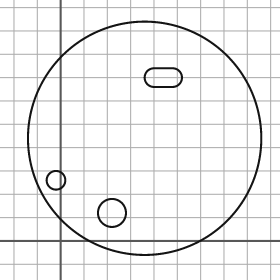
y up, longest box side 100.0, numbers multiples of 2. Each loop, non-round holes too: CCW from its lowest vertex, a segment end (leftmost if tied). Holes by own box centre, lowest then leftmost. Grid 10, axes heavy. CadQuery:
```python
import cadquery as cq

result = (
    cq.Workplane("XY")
    .moveTo(36.0, 44.0)
    .circle(50.0)
    .moveTo(22.0, 12.0)
    .circle(6.0)
    .moveTo(-2.0, 26.0)
    .circle(4.0)
    .moveTo(40.0, 66.0)
    .lineTo(48.0, 66.0)
    .threePointArc((52.0, 70.0), (48.0, 74.0))
    .lineTo(40.0, 74.0)
    .threePointArc((36.0, 70.0), (40.0, 66.0))
    .close()
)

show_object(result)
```